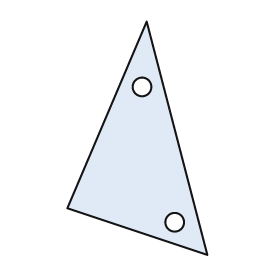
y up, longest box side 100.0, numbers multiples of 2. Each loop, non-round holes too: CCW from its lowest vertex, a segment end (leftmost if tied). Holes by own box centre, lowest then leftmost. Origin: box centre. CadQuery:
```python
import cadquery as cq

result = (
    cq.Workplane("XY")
    .moveTo(30.0, -50.0)
    .lineTo(4.0, 50.0)
    .lineTo(-30.0, -30.0)
    .close()
    .moveTo(16.0, -36.0)
    .circle(4.0)
    .moveTo(2.0, 22.0)
    .circle(4.0)
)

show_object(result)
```